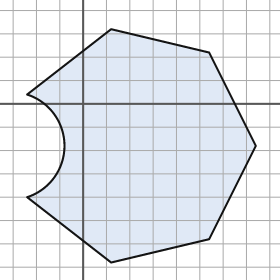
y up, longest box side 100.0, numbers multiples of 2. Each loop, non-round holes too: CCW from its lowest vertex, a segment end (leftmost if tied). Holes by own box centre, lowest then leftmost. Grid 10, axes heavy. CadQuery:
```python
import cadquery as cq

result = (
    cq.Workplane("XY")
    .moveTo(12.0, -68.0)
    .lineTo(54.0, -58.0)
    .lineTo(74.0, -18.0)
    .lineTo(54.0, 22.0)
    .lineTo(12.0, 32.0)
    .lineTo(-24.0, 4.0)
    .threePointArc((-8.0, -18.0), (-24.0, -40.0))
    .close()
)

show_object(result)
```